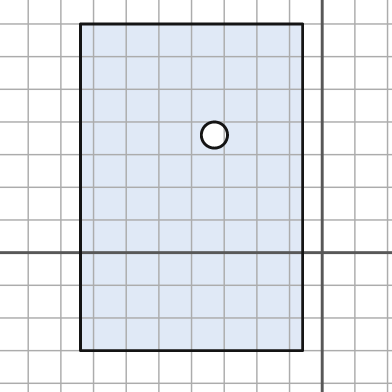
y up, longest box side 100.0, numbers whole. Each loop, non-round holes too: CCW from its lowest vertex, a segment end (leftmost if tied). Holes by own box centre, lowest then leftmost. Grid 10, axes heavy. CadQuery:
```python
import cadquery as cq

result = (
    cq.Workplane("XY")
    .moveTo(-74.0, -30.0)
    .lineTo(-6.0, -30.0)
    .lineTo(-6.0, 70.0)
    .lineTo(-74.0, 70.0)
    .close()
    .moveTo(-33.0, 36.0)
    .circle(4.0)
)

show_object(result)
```